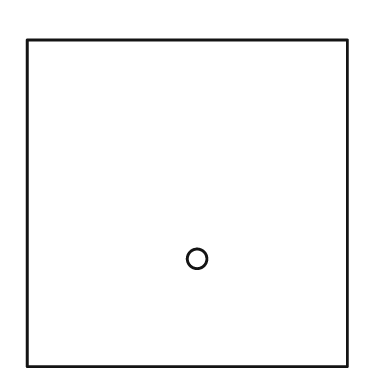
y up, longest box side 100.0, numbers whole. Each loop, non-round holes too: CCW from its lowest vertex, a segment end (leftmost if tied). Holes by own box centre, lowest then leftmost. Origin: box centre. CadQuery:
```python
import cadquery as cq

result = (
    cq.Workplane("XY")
    .moveTo(-49.0, -50.0)
    .lineTo(49.0, -50.0)
    .lineTo(49.0, 50.0)
    .lineTo(-49.0, 50.0)
    .close()
    .moveTo(3.0, -17.0)
    .circle(3.0)
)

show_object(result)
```